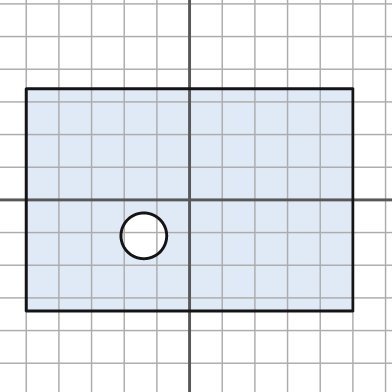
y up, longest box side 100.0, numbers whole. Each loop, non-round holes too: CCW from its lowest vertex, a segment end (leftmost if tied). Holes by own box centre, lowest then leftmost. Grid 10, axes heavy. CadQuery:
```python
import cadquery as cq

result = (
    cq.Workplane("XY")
    .moveTo(-50.0, -34.0)
    .lineTo(50.0, -34.0)
    .lineTo(50.0, 34.0)
    .lineTo(-50.0, 34.0)
    .close()
    .moveTo(-14.0, -11.0)
    .circle(7.0)
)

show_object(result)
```